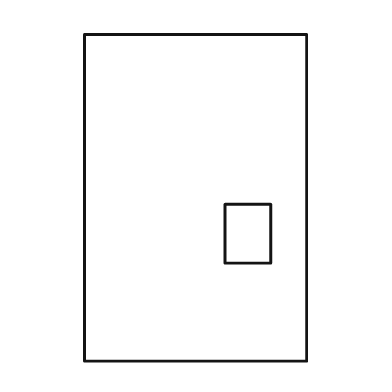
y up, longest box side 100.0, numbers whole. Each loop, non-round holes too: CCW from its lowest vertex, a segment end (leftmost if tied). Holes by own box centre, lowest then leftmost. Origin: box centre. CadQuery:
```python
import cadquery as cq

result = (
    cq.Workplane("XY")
    .moveTo(-34.0, -50.0)
    .lineTo(34.0, -50.0)
    .lineTo(34.0, 50.0)
    .lineTo(-34.0, 50.0)
    .close()
    .moveTo(9.0, -20.0)
    .lineTo(23.0, -20.0)
    .lineTo(23.0, -2.0)
    .lineTo(9.0, -2.0)
    .close()
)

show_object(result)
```